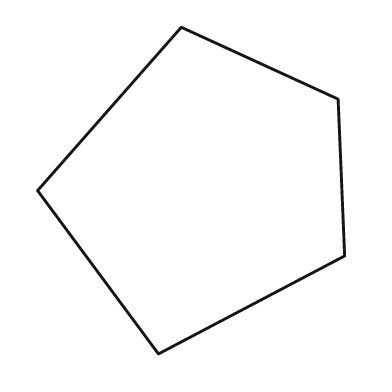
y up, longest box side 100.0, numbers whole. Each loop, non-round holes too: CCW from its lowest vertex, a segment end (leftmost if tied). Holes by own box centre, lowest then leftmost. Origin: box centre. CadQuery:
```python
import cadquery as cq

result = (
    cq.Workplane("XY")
    .moveTo(-10.0, -50.0)
    .lineTo(47.0, -20.0)
    .lineTo(45.0, 28.0)
    .lineTo(-3.0, 50.0)
    .lineTo(-47.0, 0.0)
    .close()
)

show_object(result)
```